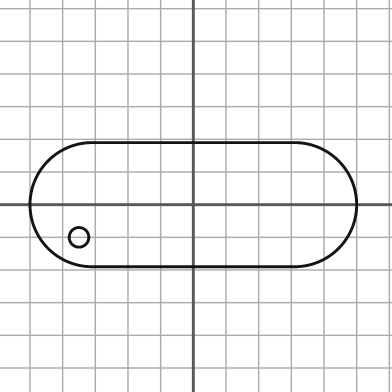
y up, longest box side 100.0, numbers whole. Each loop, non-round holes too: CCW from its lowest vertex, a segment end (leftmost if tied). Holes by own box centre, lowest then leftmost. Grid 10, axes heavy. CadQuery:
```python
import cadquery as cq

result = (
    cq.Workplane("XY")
    .moveTo(-31.0, -19.0)
    .lineTo(31.0, -19.0)
    .threePointArc((50.0, 0.0), (31.0, 19.0))
    .lineTo(-31.0, 19.0)
    .threePointArc((-50.0, 0.0), (-31.0, -19.0))
    .close()
    .moveTo(-35.0, -10.0)
    .circle(3.0)
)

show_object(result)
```